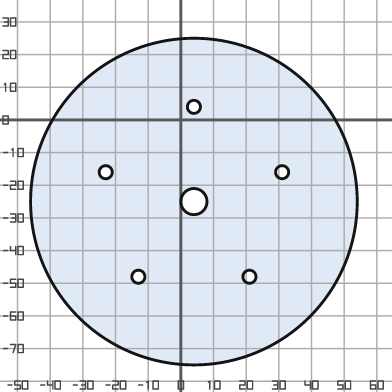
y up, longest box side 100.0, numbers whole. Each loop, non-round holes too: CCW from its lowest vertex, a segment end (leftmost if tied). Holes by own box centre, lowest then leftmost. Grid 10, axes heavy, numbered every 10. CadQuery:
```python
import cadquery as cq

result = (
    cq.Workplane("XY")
    .moveTo(4.0, -25.0)
    .circle(50.0)
    .moveTo(-13.0, -48.0)
    .circle(2.0)
    .moveTo(21.0, -48.0)
    .circle(2.0)
    .moveTo(4.0, -25.0)
    .circle(4.0)
    .moveTo(-23.0, -16.0)
    .circle(2.0)
    .moveTo(31.0, -16.0)
    .circle(2.0)
    .moveTo(4.0, 4.0)
    .circle(2.0)
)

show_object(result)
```